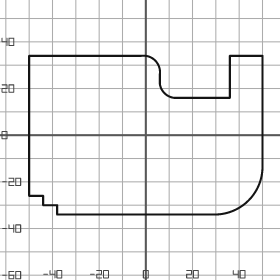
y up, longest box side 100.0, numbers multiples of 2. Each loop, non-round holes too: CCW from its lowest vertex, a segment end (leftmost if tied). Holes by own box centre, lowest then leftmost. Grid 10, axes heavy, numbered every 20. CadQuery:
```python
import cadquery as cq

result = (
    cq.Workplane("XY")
    .moveTo(-38.0, -34.0)
    .lineTo(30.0, -34.0)
    .threePointArc((44.0, -28.0), (50.0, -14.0))
    .lineTo(50.0, 34.0)
    .lineTo(36.0, 34.0)
    .lineTo(36.0, 16.0)
    .lineTo(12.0, 16.0)
    .threePointArc((8.0, 18.0), (6.0, 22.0))
    .lineTo(6.0, 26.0)
    .threePointArc((4.0, 32.0), (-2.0, 34.0))
    .lineTo(-50.0, 34.0)
    .lineTo(-50.0, -26.0)
    .lineTo(-44.0, -26.0)
    .lineTo(-44.0, -30.0)
    .lineTo(-38.0, -30.0)
    .close()
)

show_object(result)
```